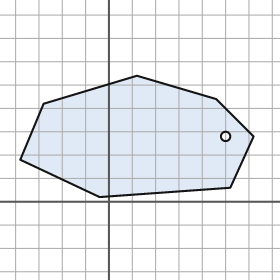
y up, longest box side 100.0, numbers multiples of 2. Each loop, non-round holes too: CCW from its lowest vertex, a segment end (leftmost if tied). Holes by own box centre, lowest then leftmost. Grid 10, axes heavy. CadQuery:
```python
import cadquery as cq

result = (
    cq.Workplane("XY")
    .moveTo(-4.0, 2.0)
    .lineTo(52.0, 6.0)
    .lineTo(62.0, 28.0)
    .lineTo(46.0, 44.0)
    .lineTo(12.0, 54.0)
    .lineTo(-28.0, 42.0)
    .lineTo(-38.0, 18.0)
    .close()
    .moveTo(50.0, 28.0)
    .circle(2.0)
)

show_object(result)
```